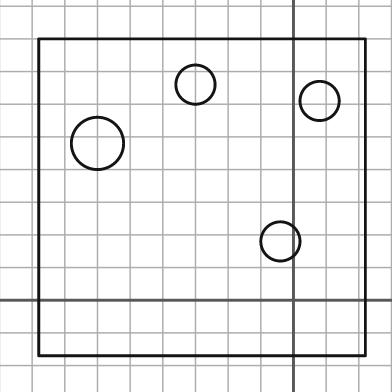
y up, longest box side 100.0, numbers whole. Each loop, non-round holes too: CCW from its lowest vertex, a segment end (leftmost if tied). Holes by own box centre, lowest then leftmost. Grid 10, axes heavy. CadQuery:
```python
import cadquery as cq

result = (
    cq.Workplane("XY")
    .moveTo(-78.0, -17.0)
    .lineTo(22.0, -17.0)
    .lineTo(22.0, 80.0)
    .lineTo(-78.0, 80.0)
    .close()
    .moveTo(-4.0, 18.0)
    .circle(6.0)
    .moveTo(-60.0, 48.0)
    .circle(8.0)
    .moveTo(8.0, 61.0)
    .circle(6.0)
    .moveTo(-30.0, 66.0)
    .circle(6.0)
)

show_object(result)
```